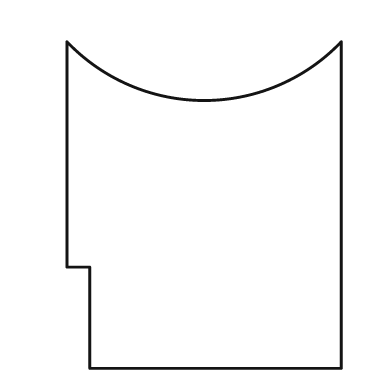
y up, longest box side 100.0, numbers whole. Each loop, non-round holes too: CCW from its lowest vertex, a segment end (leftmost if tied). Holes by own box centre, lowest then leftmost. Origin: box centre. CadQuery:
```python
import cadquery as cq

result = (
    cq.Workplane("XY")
    .moveTo(-35.0, -50.0)
    .lineTo(42.0, -50.0)
    .lineTo(42.0, 50.0)
    .threePointArc((0.0, 32.0), (-42.0, 50.0))
    .lineTo(-42.0, -19.0)
    .lineTo(-35.0, -19.0)
    .close()
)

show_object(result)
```